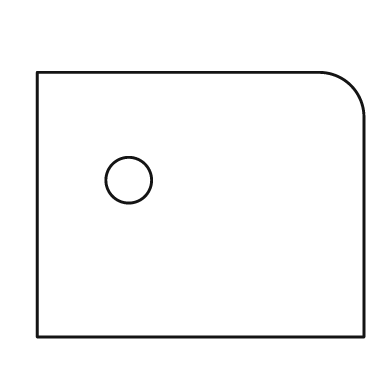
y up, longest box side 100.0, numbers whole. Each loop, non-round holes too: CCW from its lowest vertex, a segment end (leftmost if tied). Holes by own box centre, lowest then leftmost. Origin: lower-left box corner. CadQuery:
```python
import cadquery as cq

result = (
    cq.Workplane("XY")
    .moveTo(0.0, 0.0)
    .lineTo(100.0, 0.0)
    .lineTo(100.0, 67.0)
    .threePointArc((96.0, 77.0), (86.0, 81.0))
    .lineTo(0.0, 81.0)
    .close()
    .moveTo(28.0, 48.0)
    .circle(7.0)
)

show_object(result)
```